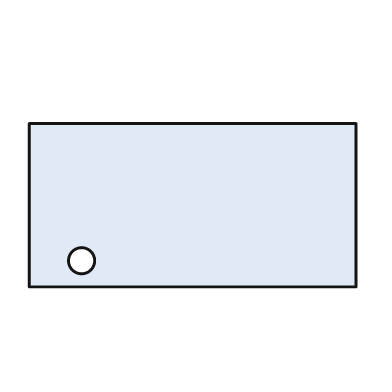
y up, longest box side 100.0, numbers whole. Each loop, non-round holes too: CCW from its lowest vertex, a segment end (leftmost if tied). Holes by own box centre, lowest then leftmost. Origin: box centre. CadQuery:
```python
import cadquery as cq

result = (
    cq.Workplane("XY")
    .moveTo(-50.0, -25.0)
    .lineTo(50.0, -25.0)
    .lineTo(50.0, 25.0)
    .lineTo(-50.0, 25.0)
    .close()
    .moveTo(-34.0, -17.0)
    .circle(4.0)
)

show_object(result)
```